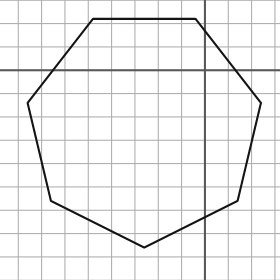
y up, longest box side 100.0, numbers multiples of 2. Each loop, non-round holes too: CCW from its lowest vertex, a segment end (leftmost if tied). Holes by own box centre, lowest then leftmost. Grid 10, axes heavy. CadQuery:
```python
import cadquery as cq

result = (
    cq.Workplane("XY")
    .moveTo(-26.0, -76.0)
    .lineTo(14.0, -56.0)
    .lineTo(24.0, -14.0)
    .lineTo(-4.0, 22.0)
    .lineTo(-48.0, 22.0)
    .lineTo(-76.0, -14.0)
    .lineTo(-66.0, -56.0)
    .close()
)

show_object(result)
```